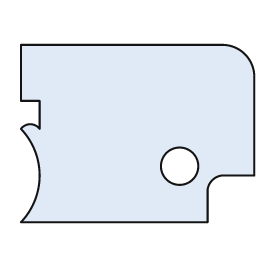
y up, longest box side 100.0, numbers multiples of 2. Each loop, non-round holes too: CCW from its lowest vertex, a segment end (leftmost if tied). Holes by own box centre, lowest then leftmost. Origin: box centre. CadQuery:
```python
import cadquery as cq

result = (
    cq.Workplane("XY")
    .moveTo(-50.0, -38.0)
    .lineTo(30.0, -38.0)
    .lineTo(30.0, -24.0)
    .threePointArc((32.0, -20.0), (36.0, -18.0))
    .lineTo(50.0, -18.0)
    .lineTo(50.0, 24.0)
    .threePointArc((46.0, 34.0), (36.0, 38.0))
    .lineTo(-50.0, 38.0)
    .lineTo(-50.0, 14.0)
    .lineTo(-42.0, 14.0)
    .lineTo(-42.0, 2.0)
    .threePointArc((-46.0, 4.0), (-50.0, 2.0))
    .threePointArc((-42.0, -18.0), (-50.0, -38.0))
    .close()
    .moveTo(18.0, -14.0)
    .circle(8.0)
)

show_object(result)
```